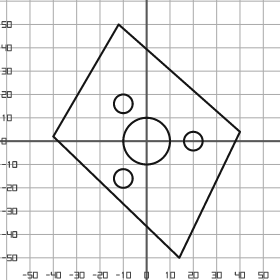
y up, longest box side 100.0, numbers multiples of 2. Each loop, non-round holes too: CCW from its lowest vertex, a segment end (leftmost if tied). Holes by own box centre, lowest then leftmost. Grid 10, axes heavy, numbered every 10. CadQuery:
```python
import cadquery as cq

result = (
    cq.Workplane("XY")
    .moveTo(14.0, -50.0)
    .lineTo(40.0, 4.0)
    .lineTo(-12.0, 50.0)
    .lineTo(-40.0, 2.0)
    .close()
    .moveTo(-10.0, -16.0)
    .circle(4.0)
    .moveTo(0.0, 0.0)
    .circle(10.0)
    .moveTo(20.0, 0.0)
    .circle(4.0)
    .moveTo(-10.0, 16.0)
    .circle(4.0)
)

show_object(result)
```